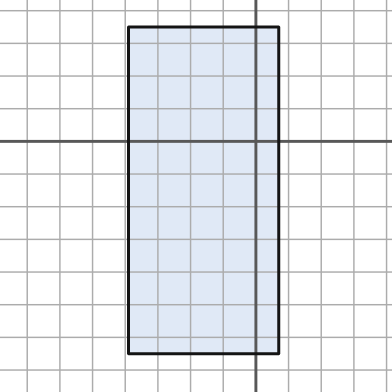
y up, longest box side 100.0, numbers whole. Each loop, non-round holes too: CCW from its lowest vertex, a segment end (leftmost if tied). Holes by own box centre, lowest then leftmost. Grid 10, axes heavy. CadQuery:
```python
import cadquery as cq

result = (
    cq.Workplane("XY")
    .moveTo(-39.0, -65.0)
    .lineTo(7.0, -65.0)
    .lineTo(7.0, 35.0)
    .lineTo(-39.0, 35.0)
    .close()
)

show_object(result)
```